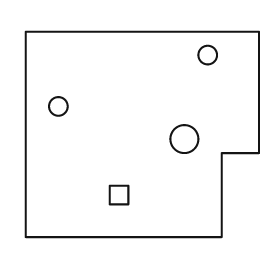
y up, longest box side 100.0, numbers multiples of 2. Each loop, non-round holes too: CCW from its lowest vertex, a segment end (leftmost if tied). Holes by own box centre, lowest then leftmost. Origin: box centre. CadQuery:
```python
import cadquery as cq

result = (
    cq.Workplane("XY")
    .moveTo(-50.0, -44.0)
    .lineTo(34.0, -44.0)
    .lineTo(34.0, -8.0)
    .lineTo(50.0, -8.0)
    .lineTo(50.0, 44.0)
    .lineTo(-50.0, 44.0)
    .close()
    .moveTo(-14.0, -30.0)
    .lineTo(-6.0, -30.0)
    .lineTo(-6.0, -22.0)
    .lineTo(-14.0, -22.0)
    .close()
    .moveTo(18.0, -2.0)
    .circle(6.0)
    .moveTo(-36.0, 12.0)
    .circle(4.0)
    .moveTo(28.0, 34.0)
    .circle(4.0)
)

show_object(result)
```